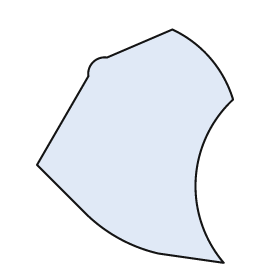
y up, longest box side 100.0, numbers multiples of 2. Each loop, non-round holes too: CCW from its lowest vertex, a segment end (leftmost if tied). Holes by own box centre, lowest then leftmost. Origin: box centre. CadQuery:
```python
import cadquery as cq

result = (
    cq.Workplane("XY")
    .moveTo(38.0, -50.0)
    .threePointArc((26.0, -14.0), (42.0, 20.0))
    .threePointArc((32.0, 38.0), (16.0, 50.0))
    .lineTo(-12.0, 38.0)
    .threePointArc((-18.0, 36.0), (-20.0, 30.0))
    .lineTo(-42.0, -8.0)
    .lineTo(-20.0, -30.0)
    .threePointArc((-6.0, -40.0), (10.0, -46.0))
    .close()
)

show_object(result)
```